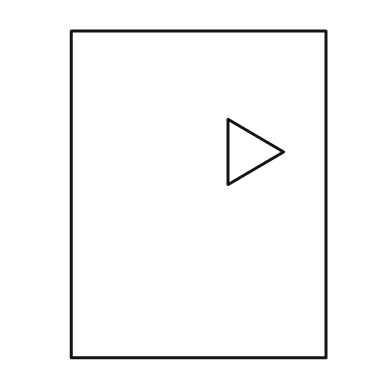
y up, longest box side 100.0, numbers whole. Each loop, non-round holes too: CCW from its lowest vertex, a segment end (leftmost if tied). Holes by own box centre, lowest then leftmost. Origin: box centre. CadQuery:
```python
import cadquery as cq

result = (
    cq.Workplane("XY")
    .moveTo(-39.0, -50.0)
    .lineTo(39.0, -50.0)
    .lineTo(39.0, 50.0)
    .lineTo(-39.0, 50.0)
    .close()
    .moveTo(9.0, 3.0)
    .lineTo(26.0, 13.0)
    .lineTo(9.0, 23.0)
    .close()
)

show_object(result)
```